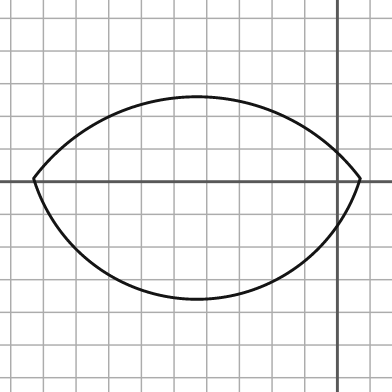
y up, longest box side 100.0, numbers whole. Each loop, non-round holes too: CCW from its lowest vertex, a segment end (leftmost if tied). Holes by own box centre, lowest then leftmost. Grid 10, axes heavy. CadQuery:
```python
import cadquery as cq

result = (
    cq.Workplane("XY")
    .moveTo(-93.0, 1.0)
    .threePointArc((-43.0, -36.0), (7.0, 1.0))
    .threePointArc((-43.0, 26.0), (-93.0, 1.0))
    .close()
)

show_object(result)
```